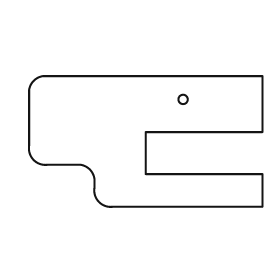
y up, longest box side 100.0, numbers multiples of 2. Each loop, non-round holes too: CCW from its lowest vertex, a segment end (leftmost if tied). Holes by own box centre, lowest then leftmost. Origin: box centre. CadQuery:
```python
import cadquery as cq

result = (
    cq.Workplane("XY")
    .moveTo(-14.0, -28.0)
    .lineTo(50.0, -28.0)
    .lineTo(50.0, -14.0)
    .lineTo(0.0, -14.0)
    .lineTo(0.0, 4.0)
    .lineTo(50.0, 4.0)
    .lineTo(50.0, 28.0)
    .lineTo(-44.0, 28.0)
    .threePointArc((-48.0, 26.0), (-50.0, 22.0))
    .lineTo(-50.0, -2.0)
    .threePointArc((-48.0, -8.0), (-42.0, -10.0))
    .lineTo(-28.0, -10.0)
    .threePointArc((-24.0, -12.0), (-22.0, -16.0))
    .lineTo(-22.0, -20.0)
    .threePointArc((-20.0, -26.0), (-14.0, -28.0))
    .close()
    .moveTo(16.0, 18.0)
    .circle(2.0)
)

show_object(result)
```